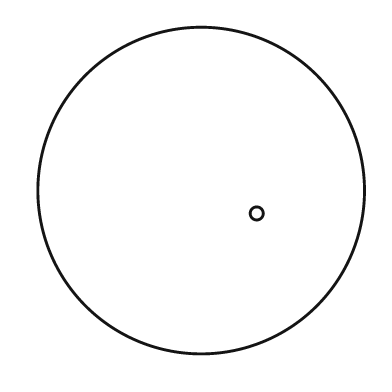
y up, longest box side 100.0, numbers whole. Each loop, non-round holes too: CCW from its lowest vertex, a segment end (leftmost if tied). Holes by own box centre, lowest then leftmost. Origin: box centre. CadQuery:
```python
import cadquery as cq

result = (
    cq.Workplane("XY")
    .moveTo(0.0, 0.0)
    .circle(50.0)
    .moveTo(17.0, -7.0)
    .circle(2.0)
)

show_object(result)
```